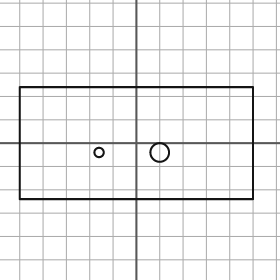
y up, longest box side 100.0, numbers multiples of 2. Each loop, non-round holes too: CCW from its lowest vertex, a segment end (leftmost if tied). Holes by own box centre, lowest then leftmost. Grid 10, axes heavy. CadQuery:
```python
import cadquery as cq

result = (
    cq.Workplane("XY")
    .moveTo(-50.0, -24.0)
    .lineTo(50.0, -24.0)
    .lineTo(50.0, 24.0)
    .lineTo(-50.0, 24.0)
    .close()
    .moveTo(-16.0, -4.0)
    .circle(2.0)
    .moveTo(10.0, -4.0)
    .circle(4.0)
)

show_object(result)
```